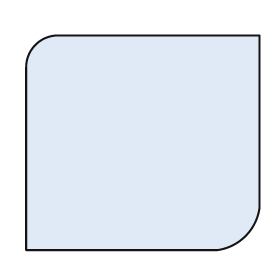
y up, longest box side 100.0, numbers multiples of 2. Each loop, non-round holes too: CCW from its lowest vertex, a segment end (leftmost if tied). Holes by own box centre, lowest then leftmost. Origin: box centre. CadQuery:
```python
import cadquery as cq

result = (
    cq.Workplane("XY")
    .moveTo(-50.0, -46.0)
    .lineTo(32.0, -46.0)
    .threePointArc((44.0, -40.0), (50.0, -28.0))
    .lineTo(50.0, 46.0)
    .lineTo(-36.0, 46.0)
    .threePointArc((-46.0, 42.0), (-50.0, 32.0))
    .close()
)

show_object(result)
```